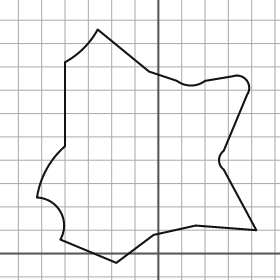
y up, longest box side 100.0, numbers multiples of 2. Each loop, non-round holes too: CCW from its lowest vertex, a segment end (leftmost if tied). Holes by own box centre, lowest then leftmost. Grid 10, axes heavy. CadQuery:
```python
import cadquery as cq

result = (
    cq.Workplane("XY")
    .moveTo(-18.0, -4.0)
    .lineTo(-2.0, 8.0)
    .lineTo(16.0, 12.0)
    .lineTo(42.0, 10.0)
    .lineTo(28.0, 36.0)
    .threePointArc((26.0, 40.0), (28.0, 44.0))
    .lineTo(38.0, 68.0)
    .threePointArc((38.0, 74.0), (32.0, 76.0))
    .lineTo(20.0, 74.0)
    .threePointArc((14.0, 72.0), (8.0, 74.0))
    .lineTo(-4.0, 78.0)
    .lineTo(-26.0, 96.0)
    .threePointArc((-32.0, 88.0), (-40.0, 82.0))
    .lineTo(-40.0, 46.0)
    .threePointArc((-48.0, 36.0), (-52.0, 24.0))
    .threePointArc((-42.0, 18.0), (-42.0, 6.0))
    .close()
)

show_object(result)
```